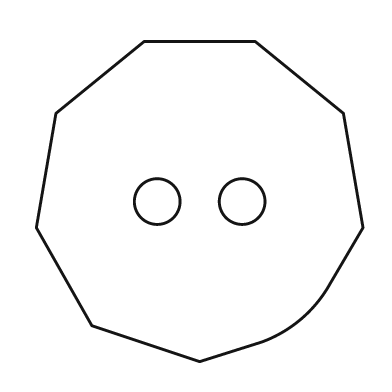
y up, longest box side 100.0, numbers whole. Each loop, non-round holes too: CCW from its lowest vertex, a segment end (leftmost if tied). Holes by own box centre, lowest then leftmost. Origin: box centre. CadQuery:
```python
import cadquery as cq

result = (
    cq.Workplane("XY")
    .moveTo(0.0, -49.0)
    .lineTo(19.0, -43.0)
    .threePointArc((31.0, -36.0), (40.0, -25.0))
    .lineTo(50.0, -8.0)
    .lineTo(44.0, 27.0)
    .lineTo(17.0, 49.0)
    .lineTo(-17.0, 49.0)
    .lineTo(-44.0, 27.0)
    .lineTo(-50.0, -8.0)
    .lineTo(-33.0, -38.0)
    .close()
    .moveTo(-13.0, 0.0)
    .circle(7.0)
    .moveTo(13.0, 0.0)
    .circle(7.0)
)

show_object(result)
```